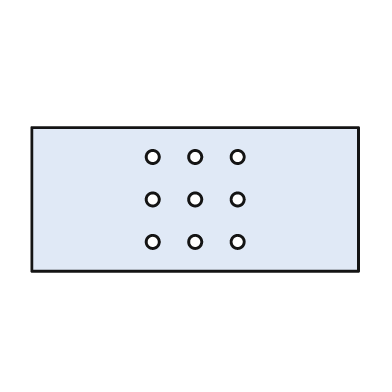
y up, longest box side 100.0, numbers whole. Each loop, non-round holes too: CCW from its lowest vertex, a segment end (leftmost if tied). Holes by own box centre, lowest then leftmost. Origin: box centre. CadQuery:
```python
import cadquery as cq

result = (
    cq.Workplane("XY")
    .moveTo(-50.0, -22.0)
    .lineTo(50.0, -22.0)
    .lineTo(50.0, 22.0)
    .lineTo(-50.0, 22.0)
    .close()
    .moveTo(-13.0, -13.0)
    .circle(2.0)
    .moveTo(0.0, -13.0)
    .circle(2.0)
    .moveTo(13.0, -13.0)
    .circle(2.0)
    .moveTo(-13.0, 0.0)
    .circle(2.0)
    .moveTo(0.0, 0.0)
    .circle(2.0)
    .moveTo(13.0, 0.0)
    .circle(2.0)
    .moveTo(-13.0, 13.0)
    .circle(2.0)
    .moveTo(0.0, 13.0)
    .circle(2.0)
    .moveTo(13.0, 13.0)
    .circle(2.0)
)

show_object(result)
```